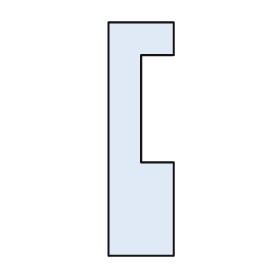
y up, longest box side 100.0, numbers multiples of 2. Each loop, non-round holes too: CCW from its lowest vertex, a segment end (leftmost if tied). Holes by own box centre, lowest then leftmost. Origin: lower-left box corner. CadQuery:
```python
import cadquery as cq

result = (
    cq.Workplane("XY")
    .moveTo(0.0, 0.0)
    .lineTo(28.0, 0.0)
    .lineTo(28.0, 40.0)
    .lineTo(14.0, 40.0)
    .lineTo(14.0, 86.0)
    .lineTo(28.0, 86.0)
    .lineTo(28.0, 100.0)
    .lineTo(0.0, 100.0)
    .close()
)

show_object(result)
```